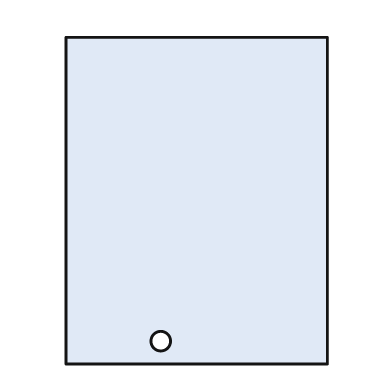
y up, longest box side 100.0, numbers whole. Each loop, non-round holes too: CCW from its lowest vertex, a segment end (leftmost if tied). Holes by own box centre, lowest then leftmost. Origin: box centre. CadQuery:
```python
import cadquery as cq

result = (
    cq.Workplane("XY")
    .moveTo(-40.0, -50.0)
    .lineTo(40.0, -50.0)
    .lineTo(40.0, 50.0)
    .lineTo(-40.0, 50.0)
    .close()
    .moveTo(-11.0, -43.0)
    .circle(3.0)
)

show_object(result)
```